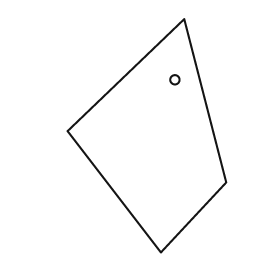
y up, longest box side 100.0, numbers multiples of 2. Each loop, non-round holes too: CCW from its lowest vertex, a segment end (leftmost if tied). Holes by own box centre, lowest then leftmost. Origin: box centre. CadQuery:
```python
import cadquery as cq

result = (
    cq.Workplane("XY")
    .moveTo(6.0, -50.0)
    .lineTo(34.0, -20.0)
    .lineTo(16.0, 50.0)
    .lineTo(-34.0, 2.0)
    .close()
    .moveTo(12.0, 24.0)
    .circle(2.0)
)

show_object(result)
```